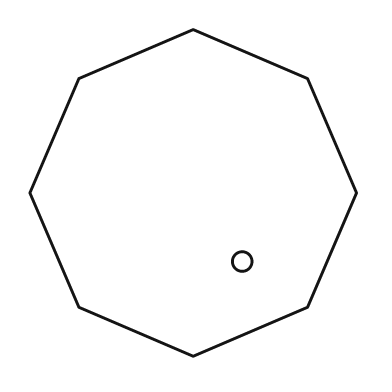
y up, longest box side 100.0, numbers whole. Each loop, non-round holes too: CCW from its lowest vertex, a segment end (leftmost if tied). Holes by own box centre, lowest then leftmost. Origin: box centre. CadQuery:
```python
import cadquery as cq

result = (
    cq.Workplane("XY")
    .moveTo(0.0, -50.0)
    .lineTo(35.0, -35.0)
    .lineTo(50.0, 0.0)
    .lineTo(35.0, 35.0)
    .lineTo(0.0, 50.0)
    .lineTo(-35.0, 35.0)
    .lineTo(-50.0, 0.0)
    .lineTo(-35.0, -35.0)
    .close()
    .moveTo(15.0, -21.0)
    .circle(3.0)
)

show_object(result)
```